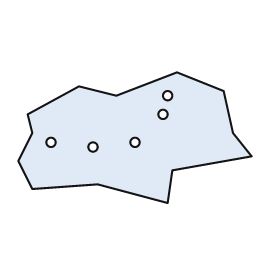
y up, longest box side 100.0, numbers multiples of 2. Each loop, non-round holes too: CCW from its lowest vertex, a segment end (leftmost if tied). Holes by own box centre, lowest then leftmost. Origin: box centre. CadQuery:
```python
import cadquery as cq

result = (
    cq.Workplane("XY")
    .moveTo(14.0, -28.0)
    .lineTo(16.0, -14.0)
    .lineTo(50.0, -8.0)
    .lineTo(42.0, 2.0)
    .lineTo(38.0, 20.0)
    .lineTo(18.0, 28.0)
    .lineTo(-8.0, 18.0)
    .lineTo(-24.0, 22.0)
    .lineTo(-46.0, 10.0)
    .lineTo(-44.0, 2.0)
    .lineTo(-50.0, -10.0)
    .lineTo(-44.0, -22.0)
    .lineTo(-16.0, -20.0)
    .close()
    .moveTo(-18.0, -4.0)
    .circle(2.0)
    .moveTo(-36.0, -2.0)
    .circle(2.0)
    .moveTo(0.0, -2.0)
    .circle(2.0)
    .moveTo(12.0, 10.0)
    .circle(2.0)
    .moveTo(14.0, 18.0)
    .circle(2.0)
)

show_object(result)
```